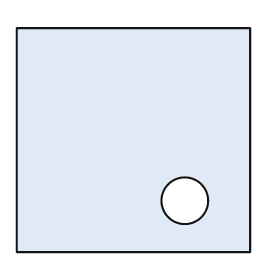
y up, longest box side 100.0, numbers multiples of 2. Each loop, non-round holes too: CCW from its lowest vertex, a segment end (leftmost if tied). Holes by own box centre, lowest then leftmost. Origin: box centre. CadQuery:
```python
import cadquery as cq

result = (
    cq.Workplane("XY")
    .moveTo(-50.0, -48.0)
    .lineTo(50.0, -48.0)
    .lineTo(50.0, 48.0)
    .lineTo(-50.0, 48.0)
    .close()
    .moveTo(22.0, -26.0)
    .circle(10.0)
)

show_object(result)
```